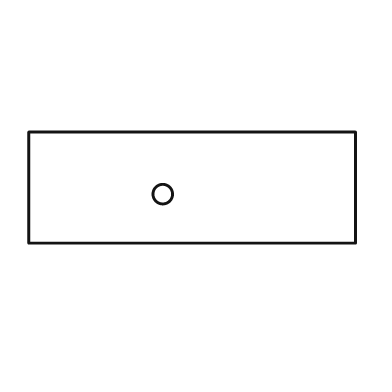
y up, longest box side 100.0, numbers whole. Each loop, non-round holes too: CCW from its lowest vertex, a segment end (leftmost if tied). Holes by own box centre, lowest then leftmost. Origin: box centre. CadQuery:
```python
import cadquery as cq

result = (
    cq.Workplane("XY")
    .moveTo(-50.0, -17.0)
    .lineTo(50.0, -17.0)
    .lineTo(50.0, 17.0)
    .lineTo(-50.0, 17.0)
    .close()
    .moveTo(-9.0, -2.0)
    .circle(3.0)
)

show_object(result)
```